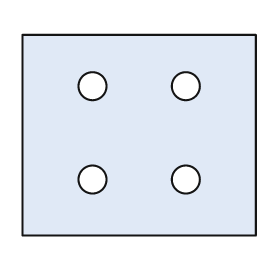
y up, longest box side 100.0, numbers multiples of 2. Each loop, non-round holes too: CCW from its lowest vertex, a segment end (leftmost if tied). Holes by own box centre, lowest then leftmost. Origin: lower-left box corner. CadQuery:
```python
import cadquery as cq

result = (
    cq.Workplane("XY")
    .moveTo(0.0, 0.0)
    .lineTo(100.0, 0.0)
    .lineTo(100.0, 86.0)
    .lineTo(0.0, 86.0)
    .close()
    .moveTo(30.0, 24.0)
    .circle(6.0)
    .moveTo(70.0, 24.0)
    .circle(6.0)
    .moveTo(30.0, 64.0)
    .circle(6.0)
    .moveTo(70.0, 64.0)
    .circle(6.0)
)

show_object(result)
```